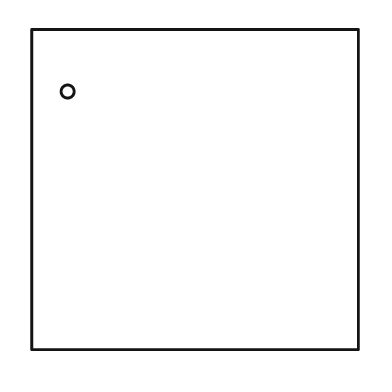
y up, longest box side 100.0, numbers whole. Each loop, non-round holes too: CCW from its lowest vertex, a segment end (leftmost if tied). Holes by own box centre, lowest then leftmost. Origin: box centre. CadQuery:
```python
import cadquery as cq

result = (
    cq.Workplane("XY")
    .moveTo(-50.0, -49.0)
    .lineTo(50.0, -49.0)
    .lineTo(50.0, 49.0)
    .lineTo(-50.0, 49.0)
    .close()
    .moveTo(-39.0, 30.0)
    .circle(2.0)
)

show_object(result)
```